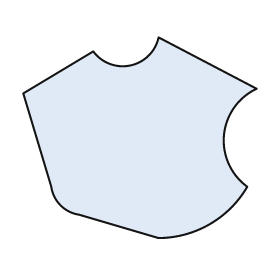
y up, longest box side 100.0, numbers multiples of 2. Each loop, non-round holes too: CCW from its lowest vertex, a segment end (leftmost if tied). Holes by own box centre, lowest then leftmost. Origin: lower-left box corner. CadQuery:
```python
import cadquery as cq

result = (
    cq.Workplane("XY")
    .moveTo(58.0, 0.0)
    .threePointArc((80.0, 6.0), (96.0, 22.0))
    .threePointArc((86.0, 44.0), (100.0, 64.0))
    .lineTo(58.0, 86.0)
    .threePointArc((46.0, 74.0), (30.0, 80.0))
    .lineTo(0.0, 62.0)
    .lineTo(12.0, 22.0)
    .threePointArc((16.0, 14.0), (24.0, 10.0))
    .close()
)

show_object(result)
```